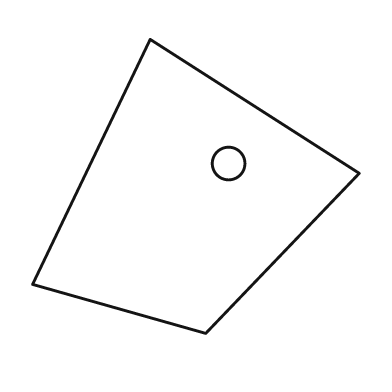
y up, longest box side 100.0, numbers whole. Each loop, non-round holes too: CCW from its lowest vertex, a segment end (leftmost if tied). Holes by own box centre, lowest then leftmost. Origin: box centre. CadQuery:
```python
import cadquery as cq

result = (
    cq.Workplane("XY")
    .moveTo(3.0, -45.0)
    .lineTo(50.0, 4.0)
    .lineTo(-14.0, 45.0)
    .lineTo(-50.0, -30.0)
    .close()
    .moveTo(10.0, 7.0)
    .circle(5.0)
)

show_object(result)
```